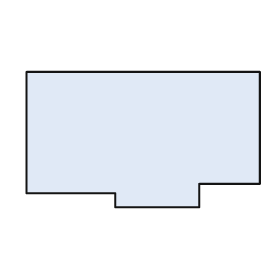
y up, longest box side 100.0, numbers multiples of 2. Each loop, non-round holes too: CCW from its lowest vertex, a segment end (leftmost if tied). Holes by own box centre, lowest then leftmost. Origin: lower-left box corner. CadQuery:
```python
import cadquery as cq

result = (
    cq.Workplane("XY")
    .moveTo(38.0, 0.0)
    .lineTo(74.0, 0.0)
    .lineTo(74.0, 10.0)
    .lineTo(100.0, 10.0)
    .lineTo(100.0, 58.0)
    .lineTo(0.0, 58.0)
    .lineTo(0.0, 6.0)
    .lineTo(38.0, 6.0)
    .close()
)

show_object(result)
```